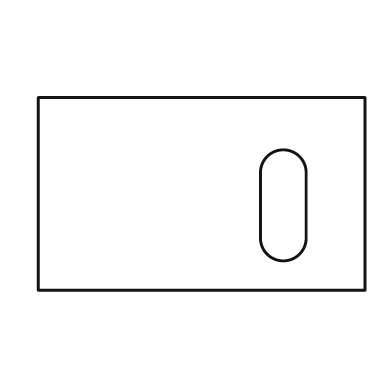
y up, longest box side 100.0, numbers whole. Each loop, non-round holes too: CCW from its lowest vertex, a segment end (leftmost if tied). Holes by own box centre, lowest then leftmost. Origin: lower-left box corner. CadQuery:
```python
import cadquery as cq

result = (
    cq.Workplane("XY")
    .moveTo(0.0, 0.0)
    .lineTo(100.0, 0.0)
    .lineTo(100.0, 59.0)
    .lineTo(0.0, 59.0)
    .close()
    .moveTo(68.0, 16.0)
    .threePointArc((75.0, 9.0), (82.0, 16.0))
    .lineTo(82.0, 36.0)
    .threePointArc((75.0, 43.0), (68.0, 36.0))
    .close()
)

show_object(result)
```